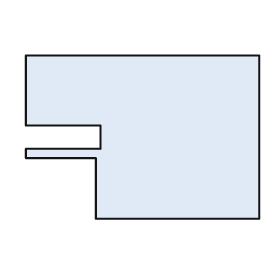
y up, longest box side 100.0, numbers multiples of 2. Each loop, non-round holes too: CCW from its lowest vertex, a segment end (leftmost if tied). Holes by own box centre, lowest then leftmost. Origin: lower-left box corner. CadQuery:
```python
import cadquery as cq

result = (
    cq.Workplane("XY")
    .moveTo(30.0, 0.0)
    .lineTo(100.0, 0.0)
    .lineTo(100.0, 70.0)
    .lineTo(0.0, 70.0)
    .lineTo(0.0, 40.0)
    .lineTo(32.0, 40.0)
    .lineTo(32.0, 30.0)
    .lineTo(0.0, 30.0)
    .lineTo(0.0, 26.0)
    .lineTo(30.0, 26.0)
    .close()
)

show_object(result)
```